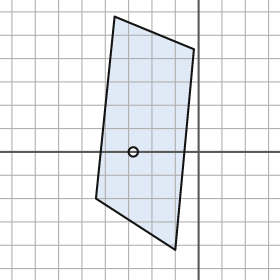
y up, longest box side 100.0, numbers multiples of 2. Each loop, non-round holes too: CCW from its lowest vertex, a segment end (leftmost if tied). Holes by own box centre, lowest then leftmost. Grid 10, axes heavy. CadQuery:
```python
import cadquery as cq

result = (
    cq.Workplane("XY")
    .moveTo(-10.0, -42.0)
    .lineTo(-2.0, 44.0)
    .lineTo(-36.0, 58.0)
    .lineTo(-44.0, -20.0)
    .close()
    .moveTo(-28.0, 0.0)
    .circle(2.0)
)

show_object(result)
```